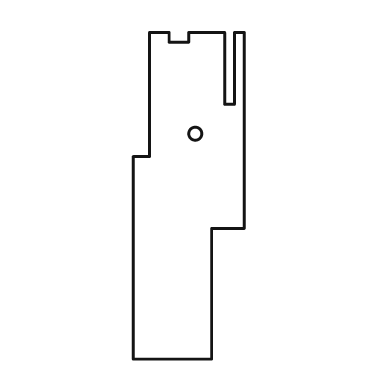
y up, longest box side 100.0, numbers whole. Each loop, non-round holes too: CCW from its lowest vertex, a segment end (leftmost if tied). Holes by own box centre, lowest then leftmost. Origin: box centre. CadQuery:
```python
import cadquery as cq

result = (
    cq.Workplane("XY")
    .moveTo(-17.0, -50.0)
    .lineTo(7.0, -50.0)
    .lineTo(7.0, -10.0)
    .lineTo(17.0, -10.0)
    .lineTo(17.0, 50.0)
    .lineTo(14.0, 50.0)
    .lineTo(14.0, 28.0)
    .lineTo(11.0, 28.0)
    .lineTo(11.0, 50.0)
    .lineTo(0.0, 50.0)
    .lineTo(0.0, 47.0)
    .lineTo(-6.0, 47.0)
    .lineTo(-6.0, 50.0)
    .lineTo(-12.0, 50.0)
    .lineTo(-12.0, 12.0)
    .lineTo(-17.0, 12.0)
    .close()
    .moveTo(2.0, 19.0)
    .circle(2.0)
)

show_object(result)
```